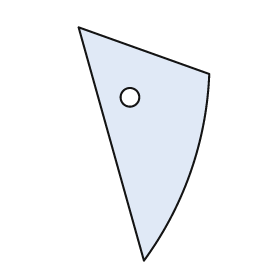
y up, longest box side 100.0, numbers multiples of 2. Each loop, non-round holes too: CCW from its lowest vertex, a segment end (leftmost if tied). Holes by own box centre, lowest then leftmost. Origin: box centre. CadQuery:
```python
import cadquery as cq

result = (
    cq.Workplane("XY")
    .moveTo(0.0, -50.0)
    .threePointArc((20.0, -12.0), (28.0, 30.0))
    .lineTo(-28.0, 50.0)
    .close()
    .moveTo(-6.0, 20.0)
    .circle(4.0)
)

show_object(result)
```